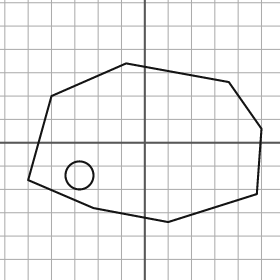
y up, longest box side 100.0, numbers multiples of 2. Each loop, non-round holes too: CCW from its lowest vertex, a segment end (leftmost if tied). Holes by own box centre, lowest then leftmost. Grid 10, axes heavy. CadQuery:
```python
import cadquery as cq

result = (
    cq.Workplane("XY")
    .moveTo(10.0, -34.0)
    .lineTo(48.0, -22.0)
    .lineTo(50.0, 6.0)
    .lineTo(36.0, 26.0)
    .lineTo(-8.0, 34.0)
    .lineTo(-40.0, 20.0)
    .lineTo(-50.0, -16.0)
    .lineTo(-22.0, -28.0)
    .close()
    .moveTo(-28.0, -14.0)
    .circle(6.0)
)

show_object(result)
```